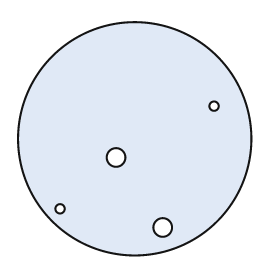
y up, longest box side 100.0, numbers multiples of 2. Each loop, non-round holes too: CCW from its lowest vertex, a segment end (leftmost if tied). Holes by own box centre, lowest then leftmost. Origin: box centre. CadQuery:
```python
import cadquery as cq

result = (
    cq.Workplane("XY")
    .moveTo(0.0, 0.0)
    .circle(50.0)
    .moveTo(12.0, -38.0)
    .circle(4.0)
    .moveTo(-32.0, -30.0)
    .circle(2.0)
    .moveTo(-8.0, -8.0)
    .circle(4.0)
    .moveTo(34.0, 14.0)
    .circle(2.0)
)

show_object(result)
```